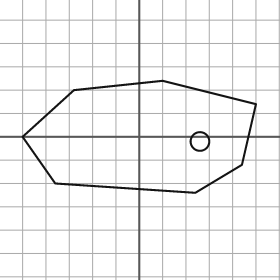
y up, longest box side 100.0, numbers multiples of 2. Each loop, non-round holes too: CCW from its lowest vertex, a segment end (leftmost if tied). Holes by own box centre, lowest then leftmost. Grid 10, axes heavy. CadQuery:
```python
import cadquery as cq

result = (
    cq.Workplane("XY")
    .moveTo(24.0, -24.0)
    .lineTo(44.0, -12.0)
    .lineTo(50.0, 14.0)
    .lineTo(10.0, 24.0)
    .lineTo(-28.0, 20.0)
    .lineTo(-50.0, 0.0)
    .lineTo(-36.0, -20.0)
    .close()
    .moveTo(26.0, -2.0)
    .circle(4.0)
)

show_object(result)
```